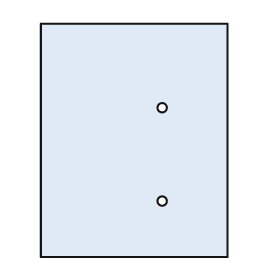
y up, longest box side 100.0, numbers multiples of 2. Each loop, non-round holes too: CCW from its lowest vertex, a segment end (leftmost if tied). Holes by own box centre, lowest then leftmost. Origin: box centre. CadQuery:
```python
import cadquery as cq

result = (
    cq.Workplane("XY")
    .moveTo(-40.0, -50.0)
    .lineTo(40.0, -50.0)
    .lineTo(40.0, 50.0)
    .lineTo(-40.0, 50.0)
    .close()
    .moveTo(12.0, -26.0)
    .circle(2.0)
    .moveTo(12.0, 14.0)
    .circle(2.0)
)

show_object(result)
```